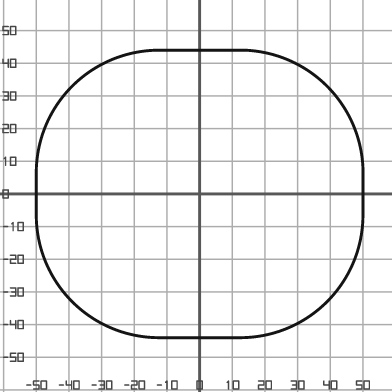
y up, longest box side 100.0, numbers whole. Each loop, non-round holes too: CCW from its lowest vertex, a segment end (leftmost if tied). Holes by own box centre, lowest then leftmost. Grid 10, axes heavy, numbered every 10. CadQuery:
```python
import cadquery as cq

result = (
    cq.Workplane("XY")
    .moveTo(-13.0, -44.0)
    .lineTo(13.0, -44.0)
    .threePointArc((39.0, -33.0), (50.0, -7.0))
    .lineTo(50.0, 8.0)
    .threePointArc((39.0, 33.0), (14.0, 44.0))
    .lineTo(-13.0, 44.0)
    .threePointArc((-39.0, 33.0), (-50.0, 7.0))
    .lineTo(-50.0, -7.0)
    .threePointArc((-39.0, -33.0), (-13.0, -44.0))
    .close()
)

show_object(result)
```